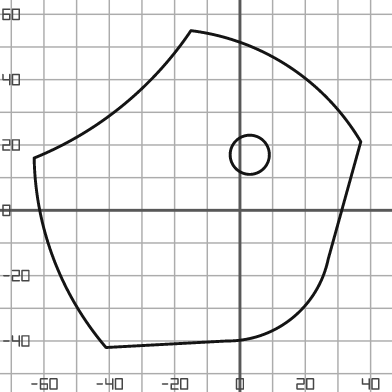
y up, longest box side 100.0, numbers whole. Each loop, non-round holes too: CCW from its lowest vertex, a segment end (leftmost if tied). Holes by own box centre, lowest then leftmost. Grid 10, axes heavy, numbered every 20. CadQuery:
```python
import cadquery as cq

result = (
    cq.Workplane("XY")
    .moveTo(-41.0, -42.0)
    .lineTo(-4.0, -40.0)
    .threePointArc((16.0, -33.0), (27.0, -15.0))
    .lineTo(37.0, 21.0)
    .threePointArc((15.0, 44.0), (-15.0, 55.0))
    .threePointArc((-36.0, 32.0), (-63.0, 16.0))
    .threePointArc((-57.0, -15.0), (-41.0, -42.0))
    .close()
    .moveTo(3.0, 17.0)
    .circle(6.0)
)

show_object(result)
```